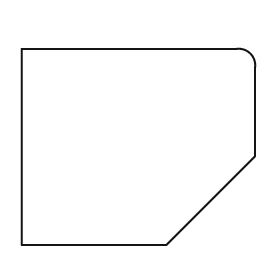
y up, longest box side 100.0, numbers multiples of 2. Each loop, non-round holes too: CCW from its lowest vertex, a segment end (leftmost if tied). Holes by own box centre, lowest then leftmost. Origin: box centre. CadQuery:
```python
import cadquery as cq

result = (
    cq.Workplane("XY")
    .moveTo(-50.0, -42.0)
    .lineTo(12.0, -42.0)
    .lineTo(50.0, -4.0)
    .lineTo(50.0, 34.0)
    .threePointArc((48.0, 40.0), (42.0, 42.0))
    .lineTo(-50.0, 42.0)
    .close()
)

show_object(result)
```